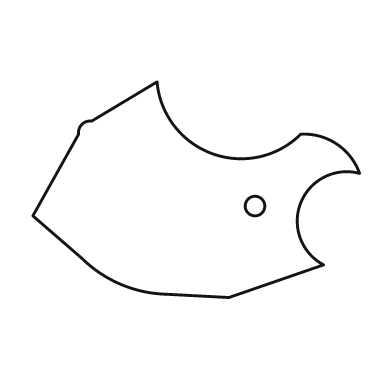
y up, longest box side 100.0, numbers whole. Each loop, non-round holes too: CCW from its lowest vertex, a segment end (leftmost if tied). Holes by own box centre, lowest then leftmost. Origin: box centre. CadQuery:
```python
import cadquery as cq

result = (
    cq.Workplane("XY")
    .moveTo(10.0, -33.0)
    .lineTo(39.0, -23.0)
    .threePointArc((32.0, -4.0), (50.0, 5.0))
    .threePointArc((43.0, 14.0), (32.0, 17.0))
    .threePointArc((5.0, 11.0), (-12.0, 33.0))
    .lineTo(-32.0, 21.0)
    .threePointArc((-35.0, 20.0), (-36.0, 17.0))
    .lineTo(-50.0, -8.0)
    .lineTo(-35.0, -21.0)
    .threePointArc((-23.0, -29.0), (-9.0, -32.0))
    .close()
    .moveTo(18.0, -5.0)
    .circle(3.0)
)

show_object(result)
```